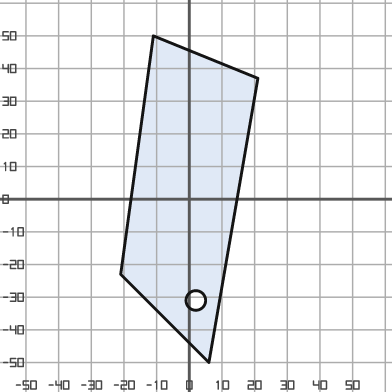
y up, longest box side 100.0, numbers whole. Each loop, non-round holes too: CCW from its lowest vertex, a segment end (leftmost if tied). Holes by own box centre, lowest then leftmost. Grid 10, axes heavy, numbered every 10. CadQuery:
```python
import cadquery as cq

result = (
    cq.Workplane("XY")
    .moveTo(6.0, -50.0)
    .lineTo(21.0, 37.0)
    .lineTo(-11.0, 50.0)
    .lineTo(-21.0, -23.0)
    .close()
    .moveTo(2.0, -31.0)
    .circle(3.0)
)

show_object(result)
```